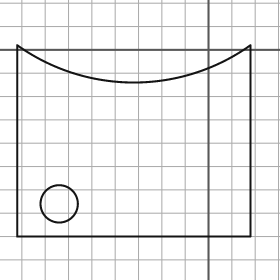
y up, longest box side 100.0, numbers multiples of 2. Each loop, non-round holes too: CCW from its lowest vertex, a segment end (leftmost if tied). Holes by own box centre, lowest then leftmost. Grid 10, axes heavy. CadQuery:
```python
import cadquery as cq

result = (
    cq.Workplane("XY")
    .moveTo(-82.0, -80.0)
    .lineTo(18.0, -80.0)
    .lineTo(18.0, 2.0)
    .threePointArc((-32.0, -14.0), (-82.0, 2.0))
    .close()
    .moveTo(-64.0, -66.0)
    .circle(8.0)
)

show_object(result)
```